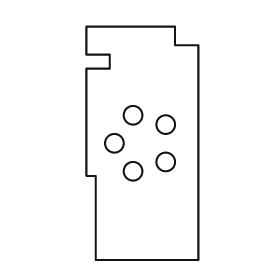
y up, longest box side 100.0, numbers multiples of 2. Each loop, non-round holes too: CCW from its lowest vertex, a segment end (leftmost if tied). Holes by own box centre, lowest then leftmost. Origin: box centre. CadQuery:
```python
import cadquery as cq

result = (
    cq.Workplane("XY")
    .moveTo(-20.0, -50.0)
    .lineTo(24.0, -50.0)
    .lineTo(24.0, 42.0)
    .lineTo(14.0, 42.0)
    .lineTo(14.0, 50.0)
    .lineTo(-24.0, 50.0)
    .lineTo(-24.0, 38.0)
    .lineTo(-14.0, 38.0)
    .lineTo(-14.0, 32.0)
    .lineTo(-24.0, 32.0)
    .lineTo(-24.0, -14.0)
    .lineTo(-20.0, -14.0)
    .close()
    .moveTo(-4.0, -12.0)
    .circle(4.0)
    .moveTo(10.0, -8.0)
    .circle(4.0)
    .moveTo(-12.0, 0.0)
    .circle(4.0)
    .moveTo(10.0, 8.0)
    .circle(4.0)
    .moveTo(-4.0, 12.0)
    .circle(4.0)
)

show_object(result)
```